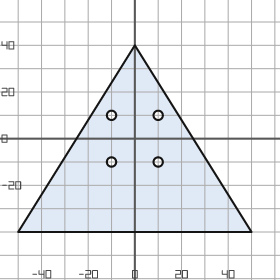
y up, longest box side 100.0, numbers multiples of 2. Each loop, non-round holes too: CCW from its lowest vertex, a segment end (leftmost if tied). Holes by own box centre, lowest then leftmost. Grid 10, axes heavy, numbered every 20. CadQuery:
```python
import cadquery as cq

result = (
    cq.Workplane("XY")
    .moveTo(-50.0, -40.0)
    .lineTo(50.0, -40.0)
    .lineTo(0.0, 40.0)
    .close()
    .moveTo(-10.0, -10.0)
    .circle(2.0)
    .moveTo(10.0, -10.0)
    .circle(2.0)
    .moveTo(-10.0, 10.0)
    .circle(2.0)
    .moveTo(10.0, 10.0)
    .circle(2.0)
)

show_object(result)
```